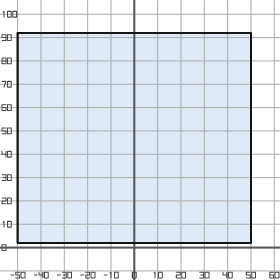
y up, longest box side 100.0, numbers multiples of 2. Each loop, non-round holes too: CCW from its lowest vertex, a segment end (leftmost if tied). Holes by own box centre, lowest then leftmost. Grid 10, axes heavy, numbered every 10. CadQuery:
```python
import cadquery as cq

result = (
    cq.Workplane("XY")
    .moveTo(-50.0, 2.0)
    .lineTo(50.0, 2.0)
    .lineTo(50.0, 92.0)
    .lineTo(-50.0, 92.0)
    .close()
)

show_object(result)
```